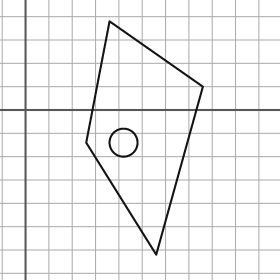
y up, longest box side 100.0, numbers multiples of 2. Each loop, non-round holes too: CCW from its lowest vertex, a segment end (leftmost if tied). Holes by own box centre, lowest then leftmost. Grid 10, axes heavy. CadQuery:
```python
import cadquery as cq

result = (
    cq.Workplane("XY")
    .moveTo(56.0, -62.0)
    .lineTo(76.0, 10.0)
    .lineTo(36.0, 38.0)
    .lineTo(26.0, -14.0)
    .close()
    .moveTo(42.0, -14.0)
    .circle(6.0)
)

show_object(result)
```